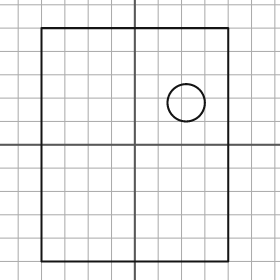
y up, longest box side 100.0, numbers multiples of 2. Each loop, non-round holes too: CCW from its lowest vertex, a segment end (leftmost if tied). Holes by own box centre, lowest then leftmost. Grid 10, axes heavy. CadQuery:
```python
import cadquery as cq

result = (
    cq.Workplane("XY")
    .moveTo(-40.0, -50.0)
    .lineTo(40.0, -50.0)
    .lineTo(40.0, 50.0)
    .lineTo(-40.0, 50.0)
    .close()
    .moveTo(22.0, 18.0)
    .circle(8.0)
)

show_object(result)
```